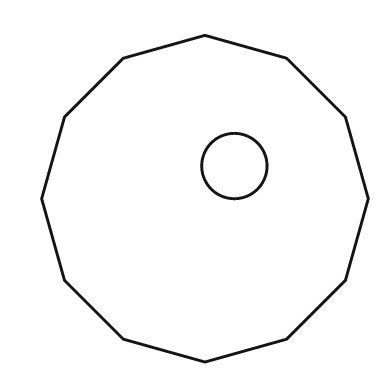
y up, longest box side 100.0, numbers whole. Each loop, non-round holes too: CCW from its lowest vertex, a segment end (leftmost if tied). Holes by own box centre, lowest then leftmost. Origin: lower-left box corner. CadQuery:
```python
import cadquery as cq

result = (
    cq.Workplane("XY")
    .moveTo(50.0, 0.0)
    .lineTo(75.0, 7.0)
    .lineTo(93.0, 25.0)
    .lineTo(100.0, 50.0)
    .lineTo(93.0, 75.0)
    .lineTo(75.0, 93.0)
    .lineTo(50.0, 100.0)
    .lineTo(25.0, 93.0)
    .lineTo(7.0, 75.0)
    .lineTo(0.0, 50.0)
    .lineTo(7.0, 25.0)
    .lineTo(25.0, 7.0)
    .close()
    .moveTo(59.0, 60.0)
    .circle(10.0)
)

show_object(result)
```